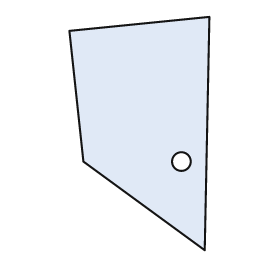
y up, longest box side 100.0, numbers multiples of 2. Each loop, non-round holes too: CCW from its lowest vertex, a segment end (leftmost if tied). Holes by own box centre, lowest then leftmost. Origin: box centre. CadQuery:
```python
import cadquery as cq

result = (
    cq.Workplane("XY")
    .moveTo(28.0, -50.0)
    .lineTo(30.0, 50.0)
    .lineTo(-30.0, 44.0)
    .lineTo(-24.0, -12.0)
    .close()
    .moveTo(18.0, -12.0)
    .circle(4.0)
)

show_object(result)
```